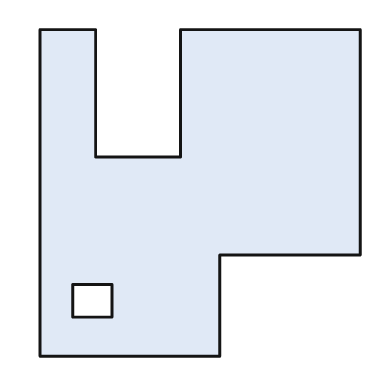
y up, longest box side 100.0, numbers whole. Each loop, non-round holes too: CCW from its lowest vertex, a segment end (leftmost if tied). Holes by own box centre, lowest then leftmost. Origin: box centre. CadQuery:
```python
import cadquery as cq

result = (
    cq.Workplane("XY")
    .moveTo(-49.0, -50.0)
    .lineTo(6.0, -50.0)
    .lineTo(6.0, -19.0)
    .lineTo(49.0, -19.0)
    .lineTo(49.0, 50.0)
    .lineTo(-6.0, 50.0)
    .lineTo(-6.0, 11.0)
    .lineTo(-32.0, 11.0)
    .lineTo(-32.0, 50.0)
    .lineTo(-49.0, 50.0)
    .close()
    .moveTo(-39.0, -38.0)
    .lineTo(-27.0, -38.0)
    .lineTo(-27.0, -28.0)
    .lineTo(-39.0, -28.0)
    .close()
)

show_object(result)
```